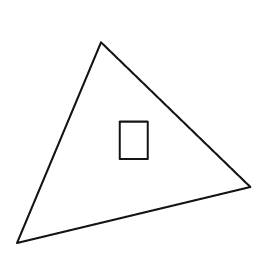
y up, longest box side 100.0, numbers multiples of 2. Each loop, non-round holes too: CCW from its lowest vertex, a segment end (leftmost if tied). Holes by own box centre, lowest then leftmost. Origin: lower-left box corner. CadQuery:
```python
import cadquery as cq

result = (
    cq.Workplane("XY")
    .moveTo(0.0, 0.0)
    .lineTo(100.0, 24.0)
    .lineTo(36.0, 86.0)
    .close()
    .moveTo(44.0, 36.0)
    .lineTo(56.0, 36.0)
    .lineTo(56.0, 52.0)
    .lineTo(44.0, 52.0)
    .close()
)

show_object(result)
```